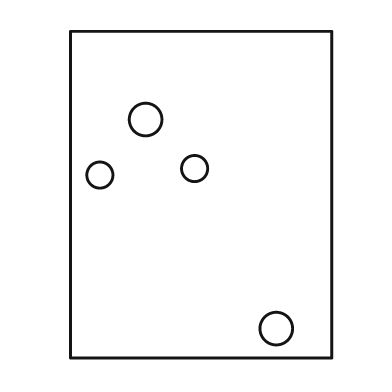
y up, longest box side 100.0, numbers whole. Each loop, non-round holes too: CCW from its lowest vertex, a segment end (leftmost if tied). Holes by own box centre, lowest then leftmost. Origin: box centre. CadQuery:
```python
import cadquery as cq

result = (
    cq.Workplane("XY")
    .moveTo(-40.0, -50.0)
    .lineTo(40.0, -50.0)
    .lineTo(40.0, 50.0)
    .lineTo(-40.0, 50.0)
    .close()
    .moveTo(23.0, -41.0)
    .circle(5.0)
    .moveTo(-31.0, 6.0)
    .circle(4.0)
    .moveTo(-2.0, 8.0)
    .circle(4.0)
    .moveTo(-17.0, 23.0)
    .circle(5.0)
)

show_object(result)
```